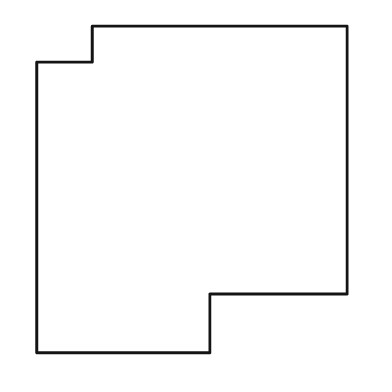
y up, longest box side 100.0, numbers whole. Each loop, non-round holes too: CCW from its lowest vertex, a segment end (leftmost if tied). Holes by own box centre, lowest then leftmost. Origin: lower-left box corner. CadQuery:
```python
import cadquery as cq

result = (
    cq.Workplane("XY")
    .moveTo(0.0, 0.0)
    .lineTo(53.0, 0.0)
    .lineTo(53.0, 18.0)
    .lineTo(95.0, 18.0)
    .lineTo(95.0, 100.0)
    .lineTo(17.0, 100.0)
    .lineTo(17.0, 89.0)
    .lineTo(0.0, 89.0)
    .close()
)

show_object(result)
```